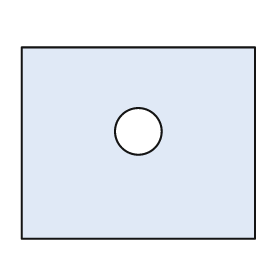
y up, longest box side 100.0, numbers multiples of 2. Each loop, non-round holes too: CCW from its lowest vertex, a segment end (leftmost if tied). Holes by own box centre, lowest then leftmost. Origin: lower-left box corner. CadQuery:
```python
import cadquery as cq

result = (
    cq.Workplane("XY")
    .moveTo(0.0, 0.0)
    .lineTo(100.0, 0.0)
    .lineTo(100.0, 82.0)
    .lineTo(0.0, 82.0)
    .close()
    .moveTo(50.0, 46.0)
    .circle(10.0)
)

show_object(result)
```